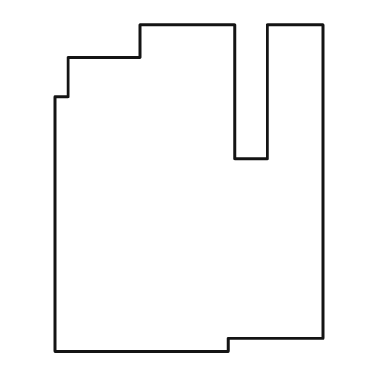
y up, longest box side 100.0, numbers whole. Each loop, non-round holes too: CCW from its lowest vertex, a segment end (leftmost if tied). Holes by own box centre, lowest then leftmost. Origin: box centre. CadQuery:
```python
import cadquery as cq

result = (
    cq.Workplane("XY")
    .moveTo(-41.0, -50.0)
    .lineTo(12.0, -50.0)
    .lineTo(12.0, -46.0)
    .lineTo(41.0, -46.0)
    .lineTo(41.0, 50.0)
    .lineTo(24.0, 50.0)
    .lineTo(24.0, 9.0)
    .lineTo(14.0, 9.0)
    .lineTo(14.0, 50.0)
    .lineTo(-15.0, 50.0)
    .lineTo(-15.0, 40.0)
    .lineTo(-37.0, 40.0)
    .lineTo(-37.0, 28.0)
    .lineTo(-41.0, 28.0)
    .close()
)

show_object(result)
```